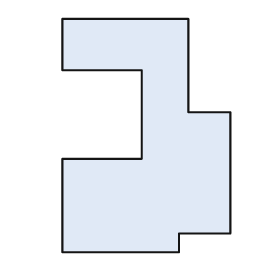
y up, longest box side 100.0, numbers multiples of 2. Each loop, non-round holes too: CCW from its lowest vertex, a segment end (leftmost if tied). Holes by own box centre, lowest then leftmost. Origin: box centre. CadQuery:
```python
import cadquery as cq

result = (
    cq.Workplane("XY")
    .moveTo(-36.0, -50.0)
    .lineTo(14.0, -50.0)
    .lineTo(14.0, -42.0)
    .lineTo(36.0, -42.0)
    .lineTo(36.0, 10.0)
    .lineTo(18.0, 10.0)
    .lineTo(18.0, 50.0)
    .lineTo(-36.0, 50.0)
    .lineTo(-36.0, 28.0)
    .lineTo(-2.0, 28.0)
    .lineTo(-2.0, -10.0)
    .lineTo(-36.0, -10.0)
    .close()
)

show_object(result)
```